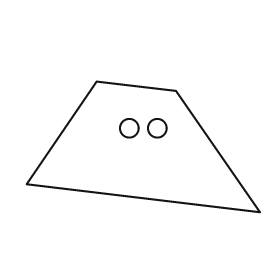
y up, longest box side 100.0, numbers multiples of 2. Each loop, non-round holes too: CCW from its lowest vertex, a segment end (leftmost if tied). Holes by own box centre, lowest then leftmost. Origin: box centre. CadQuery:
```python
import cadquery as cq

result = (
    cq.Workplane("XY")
    .moveTo(50.0, -28.0)
    .lineTo(14.0, 24.0)
    .lineTo(-20.0, 28.0)
    .lineTo(-50.0, -16.0)
    .close()
    .moveTo(-6.0, 8.0)
    .circle(4.0)
    .moveTo(6.0, 8.0)
    .circle(4.0)
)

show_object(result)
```